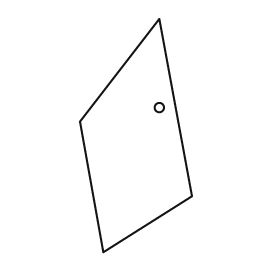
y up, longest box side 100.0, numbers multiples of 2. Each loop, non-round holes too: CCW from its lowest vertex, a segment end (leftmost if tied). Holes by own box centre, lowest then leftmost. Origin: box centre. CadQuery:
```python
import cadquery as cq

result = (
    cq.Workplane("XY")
    .moveTo(-14.0, -50.0)
    .lineTo(24.0, -26.0)
    .lineTo(10.0, 50.0)
    .lineTo(-24.0, 6.0)
    .close()
    .moveTo(10.0, 12.0)
    .circle(2.0)
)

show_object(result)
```